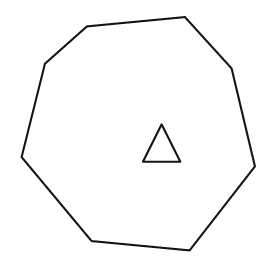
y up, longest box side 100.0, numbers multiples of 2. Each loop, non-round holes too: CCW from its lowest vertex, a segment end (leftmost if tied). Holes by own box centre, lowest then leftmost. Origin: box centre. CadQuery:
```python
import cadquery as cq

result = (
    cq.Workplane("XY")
    .moveTo(22.0, -50.0)
    .lineTo(50.0, -14.0)
    .lineTo(40.0, 28.0)
    .lineTo(20.0, 50.0)
    .lineTo(-22.0, 46.0)
    .lineTo(-40.0, 30.0)
    .lineTo(-50.0, -10.0)
    .lineTo(-20.0, -46.0)
    .close()
    .moveTo(2.0, -12.0)
    .lineTo(18.0, -12.0)
    .lineTo(10.0, 4.0)
    .close()
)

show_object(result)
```